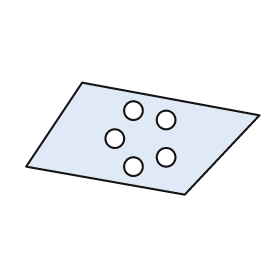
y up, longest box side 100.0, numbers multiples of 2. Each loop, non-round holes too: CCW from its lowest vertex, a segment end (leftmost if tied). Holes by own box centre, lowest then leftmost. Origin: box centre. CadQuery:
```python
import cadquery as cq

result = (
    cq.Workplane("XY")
    .moveTo(18.0, -24.0)
    .lineTo(50.0, 10.0)
    .lineTo(-26.0, 24.0)
    .lineTo(-50.0, -12.0)
    .close()
    .moveTo(-4.0, -12.0)
    .circle(4.0)
    .moveTo(10.0, -8.0)
    .circle(4.0)
    .moveTo(-12.0, 0.0)
    .circle(4.0)
    .moveTo(10.0, 8.0)
    .circle(4.0)
    .moveTo(-4.0, 12.0)
    .circle(4.0)
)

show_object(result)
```